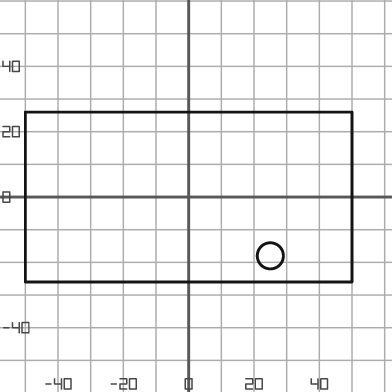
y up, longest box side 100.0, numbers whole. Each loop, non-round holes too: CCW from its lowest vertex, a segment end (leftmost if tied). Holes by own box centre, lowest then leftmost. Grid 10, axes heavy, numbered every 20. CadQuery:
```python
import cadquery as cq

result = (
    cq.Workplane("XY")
    .moveTo(-50.0, -26.0)
    .lineTo(50.0, -26.0)
    .lineTo(50.0, 26.0)
    .lineTo(-50.0, 26.0)
    .close()
    .moveTo(25.0, -18.0)
    .circle(4.0)
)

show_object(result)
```